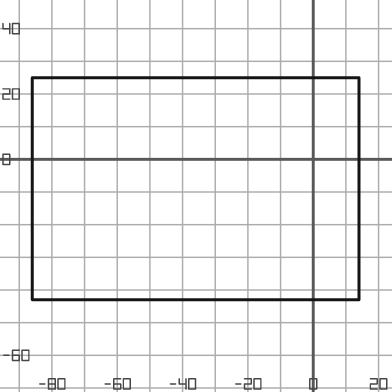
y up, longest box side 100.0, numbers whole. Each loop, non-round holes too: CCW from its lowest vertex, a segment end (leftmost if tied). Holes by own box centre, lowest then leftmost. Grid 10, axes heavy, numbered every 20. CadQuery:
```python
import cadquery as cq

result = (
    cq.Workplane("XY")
    .moveTo(-86.0, -43.0)
    .lineTo(14.0, -43.0)
    .lineTo(14.0, 25.0)
    .lineTo(-86.0, 25.0)
    .close()
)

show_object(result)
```